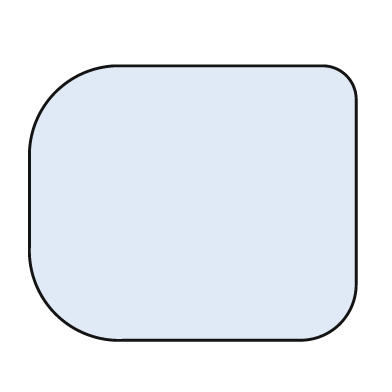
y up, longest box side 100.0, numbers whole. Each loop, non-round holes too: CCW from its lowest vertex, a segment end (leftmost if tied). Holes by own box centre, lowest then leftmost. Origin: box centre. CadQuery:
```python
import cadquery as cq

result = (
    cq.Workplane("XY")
    .moveTo(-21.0, -42.0)
    .lineTo(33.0, -42.0)
    .threePointArc((45.0, -37.0), (50.0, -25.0))
    .lineTo(50.0, 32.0)
    .threePointArc((47.0, 39.0), (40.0, 42.0))
    .lineTo(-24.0, 42.0)
    .threePointArc((-42.0, 34.0), (-50.0, 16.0))
    .lineTo(-50.0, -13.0)
    .threePointArc((-42.0, -34.0), (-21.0, -42.0))
    .close()
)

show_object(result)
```